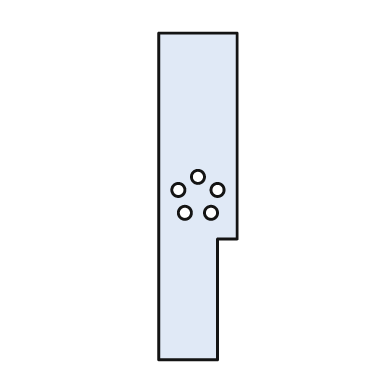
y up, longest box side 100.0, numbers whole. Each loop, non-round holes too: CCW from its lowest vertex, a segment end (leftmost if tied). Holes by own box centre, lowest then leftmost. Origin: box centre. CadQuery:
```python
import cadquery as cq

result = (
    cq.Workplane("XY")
    .moveTo(-12.0, -50.0)
    .lineTo(6.0, -50.0)
    .lineTo(6.0, -13.0)
    .lineTo(12.0, -13.0)
    .lineTo(12.0, 50.0)
    .lineTo(-12.0, 50.0)
    .close()
    .moveTo(-4.0, -5.0)
    .circle(2.0)
    .moveTo(4.0, -5.0)
    .circle(2.0)
    .moveTo(-6.0, 2.0)
    .circle(2.0)
    .moveTo(6.0, 2.0)
    .circle(2.0)
    .moveTo(0.0, 6.0)
    .circle(2.0)
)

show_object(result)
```